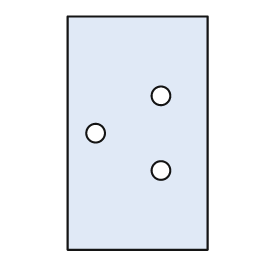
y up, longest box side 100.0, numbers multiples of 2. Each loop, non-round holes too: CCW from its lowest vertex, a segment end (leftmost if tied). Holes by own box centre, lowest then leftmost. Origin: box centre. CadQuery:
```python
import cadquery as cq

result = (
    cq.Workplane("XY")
    .moveTo(-30.0, -50.0)
    .lineTo(30.0, -50.0)
    .lineTo(30.0, 50.0)
    .lineTo(-30.0, 50.0)
    .close()
    .moveTo(10.0, -16.0)
    .circle(4.0)
    .moveTo(-18.0, 0.0)
    .circle(4.0)
    .moveTo(10.0, 16.0)
    .circle(4.0)
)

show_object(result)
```